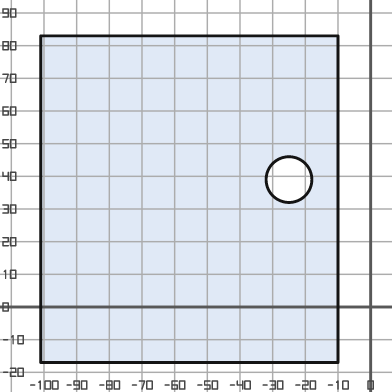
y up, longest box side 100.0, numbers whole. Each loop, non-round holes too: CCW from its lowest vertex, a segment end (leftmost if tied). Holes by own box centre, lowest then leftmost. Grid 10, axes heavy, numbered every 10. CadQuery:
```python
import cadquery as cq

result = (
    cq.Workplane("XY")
    .moveTo(-101.0, -17.0)
    .lineTo(-10.0, -17.0)
    .lineTo(-10.0, 83.0)
    .lineTo(-101.0, 83.0)
    .close()
    .moveTo(-25.0, 39.0)
    .circle(7.0)
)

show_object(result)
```